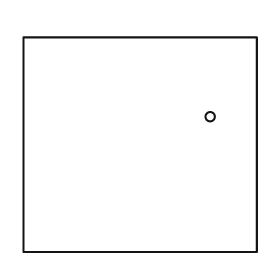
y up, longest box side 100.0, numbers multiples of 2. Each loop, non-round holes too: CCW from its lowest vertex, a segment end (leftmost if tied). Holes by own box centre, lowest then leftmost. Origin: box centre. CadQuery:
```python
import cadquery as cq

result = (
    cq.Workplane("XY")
    .moveTo(-50.0, -46.0)
    .lineTo(50.0, -46.0)
    .lineTo(50.0, 46.0)
    .lineTo(-50.0, 46.0)
    .close()
    .moveTo(30.0, 12.0)
    .circle(2.0)
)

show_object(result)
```